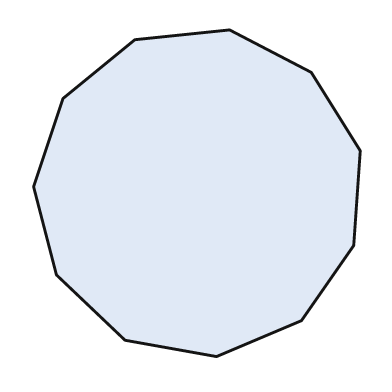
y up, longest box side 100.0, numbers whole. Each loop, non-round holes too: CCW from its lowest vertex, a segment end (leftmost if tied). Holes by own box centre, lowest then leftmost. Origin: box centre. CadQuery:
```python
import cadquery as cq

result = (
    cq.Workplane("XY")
    .moveTo(6.0, -50.0)
    .lineTo(32.0, -39.0)
    .lineTo(48.0, -16.0)
    .lineTo(50.0, 13.0)
    .lineTo(35.0, 37.0)
    .lineTo(10.0, 50.0)
    .lineTo(-19.0, 47.0)
    .lineTo(-41.0, 29.0)
    .lineTo(-50.0, 2.0)
    .lineTo(-43.0, -25.0)
    .lineTo(-22.0, -45.0)
    .close()
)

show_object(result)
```